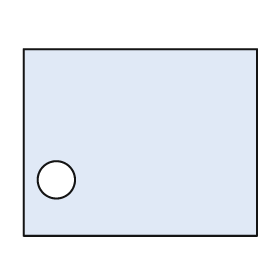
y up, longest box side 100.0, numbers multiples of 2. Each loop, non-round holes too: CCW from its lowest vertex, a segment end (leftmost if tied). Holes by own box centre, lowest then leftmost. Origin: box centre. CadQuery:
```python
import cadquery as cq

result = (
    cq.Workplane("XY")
    .moveTo(-50.0, -40.0)
    .lineTo(50.0, -40.0)
    .lineTo(50.0, 40.0)
    .lineTo(-50.0, 40.0)
    .close()
    .moveTo(-36.0, -16.0)
    .circle(8.0)
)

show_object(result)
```